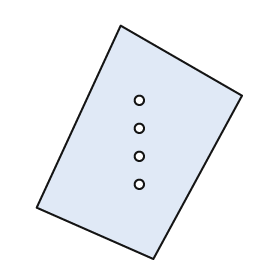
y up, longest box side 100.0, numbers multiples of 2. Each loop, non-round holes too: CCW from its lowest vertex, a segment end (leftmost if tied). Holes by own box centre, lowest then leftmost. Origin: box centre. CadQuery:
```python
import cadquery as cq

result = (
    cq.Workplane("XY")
    .moveTo(6.0, -50.0)
    .lineTo(44.0, 20.0)
    .lineTo(-8.0, 50.0)
    .lineTo(-44.0, -28.0)
    .close()
    .moveTo(0.0, -18.0)
    .circle(2.0)
    .moveTo(0.0, -6.0)
    .circle(2.0)
    .moveTo(0.0, 6.0)
    .circle(2.0)
    .moveTo(0.0, 18.0)
    .circle(2.0)
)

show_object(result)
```